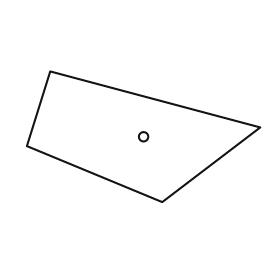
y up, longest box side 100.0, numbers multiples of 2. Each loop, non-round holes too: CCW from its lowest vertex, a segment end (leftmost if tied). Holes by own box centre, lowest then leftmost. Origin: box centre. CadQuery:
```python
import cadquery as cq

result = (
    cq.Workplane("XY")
    .moveTo(8.0, -28.0)
    .lineTo(50.0, 4.0)
    .lineTo(-40.0, 28.0)
    .lineTo(-50.0, -4.0)
    .close()
    .moveTo(0.0, 0.0)
    .circle(2.0)
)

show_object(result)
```